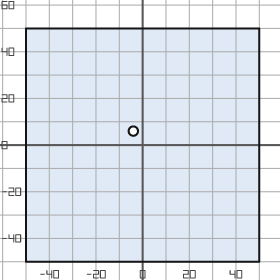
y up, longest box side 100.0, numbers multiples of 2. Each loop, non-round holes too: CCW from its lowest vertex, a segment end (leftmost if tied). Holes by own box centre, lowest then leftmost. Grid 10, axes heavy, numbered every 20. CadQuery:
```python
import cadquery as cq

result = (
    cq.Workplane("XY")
    .moveTo(-50.0, -50.0)
    .lineTo(50.0, -50.0)
    .lineTo(50.0, 50.0)
    .lineTo(-50.0, 50.0)
    .close()
    .moveTo(-4.0, 6.0)
    .circle(2.0)
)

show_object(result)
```